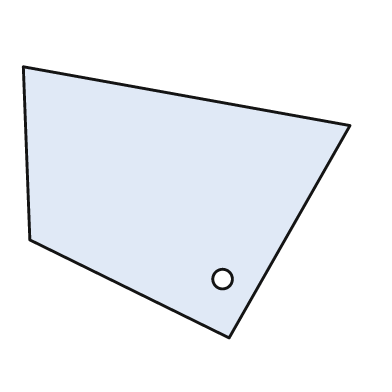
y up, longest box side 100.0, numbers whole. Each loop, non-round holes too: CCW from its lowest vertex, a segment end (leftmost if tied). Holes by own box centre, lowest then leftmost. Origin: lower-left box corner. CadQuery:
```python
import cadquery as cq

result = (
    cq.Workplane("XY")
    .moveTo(63.0, 0.0)
    .lineTo(100.0, 65.0)
    .lineTo(0.0, 83.0)
    .lineTo(2.0, 30.0)
    .close()
    .moveTo(61.0, 18.0)
    .circle(3.0)
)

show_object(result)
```